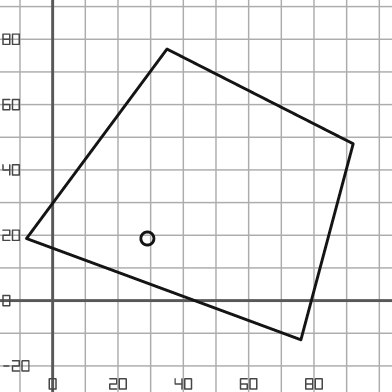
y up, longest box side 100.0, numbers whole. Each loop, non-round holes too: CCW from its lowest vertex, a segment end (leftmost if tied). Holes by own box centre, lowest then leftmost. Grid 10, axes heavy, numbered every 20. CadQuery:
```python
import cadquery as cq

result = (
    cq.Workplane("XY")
    .moveTo(76.0, -12.0)
    .lineTo(92.0, 48.0)
    .lineTo(35.0, 77.0)
    .lineTo(-8.0, 19.0)
    .close()
    .moveTo(29.0, 19.0)
    .circle(2.0)
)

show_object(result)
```